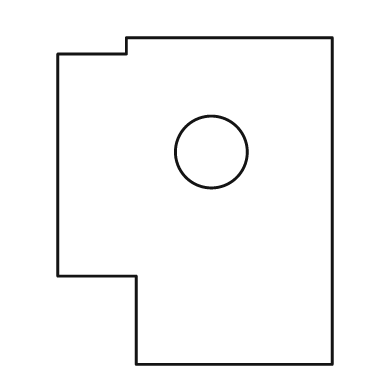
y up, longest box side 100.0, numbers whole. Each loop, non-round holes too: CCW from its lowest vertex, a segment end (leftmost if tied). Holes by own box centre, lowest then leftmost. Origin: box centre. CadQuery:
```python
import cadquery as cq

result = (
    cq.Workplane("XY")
    .moveTo(-18.0, -50.0)
    .lineTo(42.0, -50.0)
    .lineTo(42.0, 50.0)
    .lineTo(-21.0, 50.0)
    .lineTo(-21.0, 45.0)
    .lineTo(-42.0, 45.0)
    .lineTo(-42.0, -23.0)
    .lineTo(-18.0, -23.0)
    .close()
    .moveTo(5.0, 15.0)
    .circle(11.0)
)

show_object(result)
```